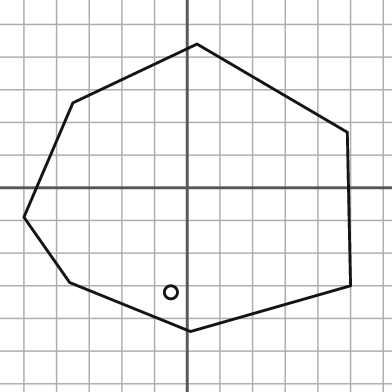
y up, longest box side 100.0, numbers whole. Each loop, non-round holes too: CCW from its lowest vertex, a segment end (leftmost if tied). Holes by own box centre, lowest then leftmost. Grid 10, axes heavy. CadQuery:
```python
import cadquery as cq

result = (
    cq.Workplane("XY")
    .moveTo(1.0, -44.0)
    .lineTo(50.0, -30.0)
    .lineTo(49.0, 17.0)
    .lineTo(3.0, 44.0)
    .lineTo(-35.0, 26.0)
    .lineTo(-50.0, -9.0)
    .lineTo(-36.0, -29.0)
    .close()
    .moveTo(-5.0, -32.0)
    .circle(2.0)
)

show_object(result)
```